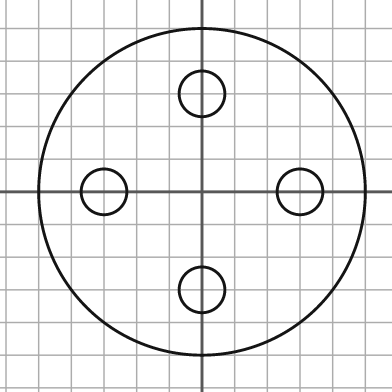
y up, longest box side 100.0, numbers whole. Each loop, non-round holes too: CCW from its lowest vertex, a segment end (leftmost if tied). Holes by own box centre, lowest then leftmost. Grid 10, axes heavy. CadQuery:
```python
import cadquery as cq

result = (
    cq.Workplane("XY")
    .moveTo(0.0, 0.0)
    .circle(50.0)
    .moveTo(0.0, -30.0)
    .circle(7.0)
    .moveTo(-30.0, 0.0)
    .circle(7.0)
    .moveTo(30.0, 0.0)
    .circle(7.0)
    .moveTo(0.0, 30.0)
    .circle(7.0)
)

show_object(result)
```